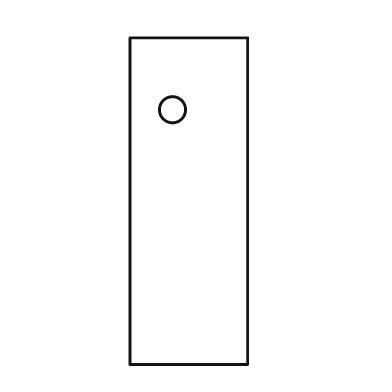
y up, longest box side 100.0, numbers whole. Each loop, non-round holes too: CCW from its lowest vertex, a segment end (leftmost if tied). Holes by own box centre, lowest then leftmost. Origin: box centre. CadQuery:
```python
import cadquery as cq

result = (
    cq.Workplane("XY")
    .moveTo(-18.0, -50.0)
    .lineTo(18.0, -50.0)
    .lineTo(18.0, 50.0)
    .lineTo(-18.0, 50.0)
    .close()
    .moveTo(-5.0, 28.0)
    .circle(4.0)
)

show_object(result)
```